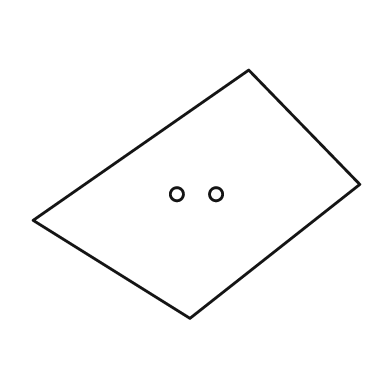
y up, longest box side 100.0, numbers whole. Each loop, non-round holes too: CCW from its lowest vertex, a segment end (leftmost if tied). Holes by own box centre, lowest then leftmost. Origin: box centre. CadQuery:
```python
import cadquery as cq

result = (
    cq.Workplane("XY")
    .moveTo(-2.0, -38.0)
    .lineTo(50.0, 3.0)
    .lineTo(16.0, 38.0)
    .lineTo(-50.0, -8.0)
    .close()
    .moveTo(-6.0, 0.0)
    .circle(2.0)
    .moveTo(6.0, 0.0)
    .circle(2.0)
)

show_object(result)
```